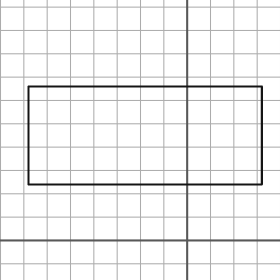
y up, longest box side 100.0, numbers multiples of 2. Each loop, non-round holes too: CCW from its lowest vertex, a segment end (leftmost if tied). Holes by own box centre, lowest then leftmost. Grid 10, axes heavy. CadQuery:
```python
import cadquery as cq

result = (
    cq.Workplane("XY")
    .moveTo(-68.0, 24.0)
    .lineTo(32.0, 24.0)
    .lineTo(32.0, 66.0)
    .lineTo(-68.0, 66.0)
    .close()
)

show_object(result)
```